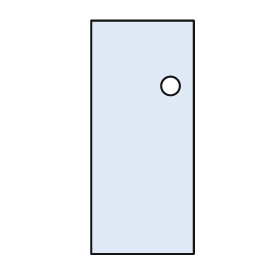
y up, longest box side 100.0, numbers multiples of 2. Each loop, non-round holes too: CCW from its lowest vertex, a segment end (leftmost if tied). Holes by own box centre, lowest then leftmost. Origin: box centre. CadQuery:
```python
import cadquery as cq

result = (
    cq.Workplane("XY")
    .moveTo(-22.0, -50.0)
    .lineTo(22.0, -50.0)
    .lineTo(22.0, 50.0)
    .lineTo(-22.0, 50.0)
    .close()
    .moveTo(12.0, 22.0)
    .circle(4.0)
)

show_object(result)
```